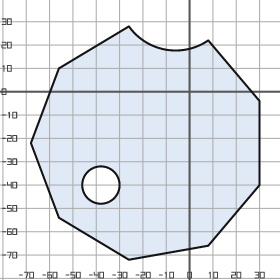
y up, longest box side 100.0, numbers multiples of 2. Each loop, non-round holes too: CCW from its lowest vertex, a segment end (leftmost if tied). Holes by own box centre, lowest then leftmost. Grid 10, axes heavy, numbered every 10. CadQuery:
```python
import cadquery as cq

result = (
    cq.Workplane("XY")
    .moveTo(-26.0, -72.0)
    .lineTo(8.0, -66.0)
    .lineTo(30.0, -40.0)
    .lineTo(30.0, -4.0)
    .lineTo(8.0, 22.0)
    .threePointArc((-10.0, 18.0), (-26.0, 28.0))
    .lineTo(-56.0, 10.0)
    .lineTo(-68.0, -22.0)
    .lineTo(-56.0, -54.0)
    .close()
    .moveTo(-38.0, -40.0)
    .circle(8.0)
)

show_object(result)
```